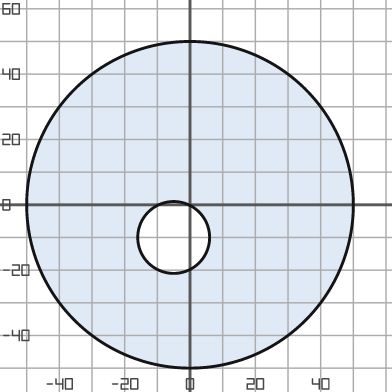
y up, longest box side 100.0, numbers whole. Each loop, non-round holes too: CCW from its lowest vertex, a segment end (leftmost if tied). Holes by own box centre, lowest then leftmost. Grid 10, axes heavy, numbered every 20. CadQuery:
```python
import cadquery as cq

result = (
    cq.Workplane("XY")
    .moveTo(0.0, 0.0)
    .circle(50.0)
    .moveTo(-5.0, -10.0)
    .circle(11.0)
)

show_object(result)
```